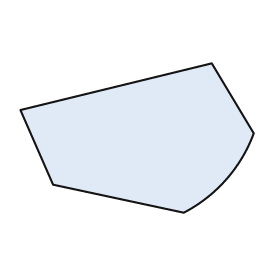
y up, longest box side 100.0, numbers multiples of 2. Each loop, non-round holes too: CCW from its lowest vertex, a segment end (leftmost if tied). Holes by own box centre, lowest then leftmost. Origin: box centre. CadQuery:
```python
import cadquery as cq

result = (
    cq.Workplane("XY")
    .moveTo(20.0, -32.0)
    .threePointArc((38.0, -18.0), (50.0, 2.0))
    .lineTo(32.0, 32.0)
    .lineTo(-50.0, 12.0)
    .lineTo(-36.0, -20.0)
    .close()
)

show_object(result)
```